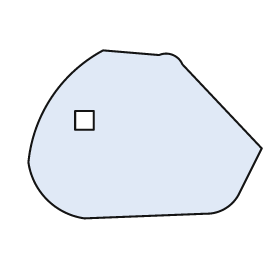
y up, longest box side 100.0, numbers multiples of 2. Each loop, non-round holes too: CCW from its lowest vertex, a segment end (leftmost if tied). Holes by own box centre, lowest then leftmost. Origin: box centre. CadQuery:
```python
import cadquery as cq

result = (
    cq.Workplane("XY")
    .moveTo(-26.0, -36.0)
    .lineTo(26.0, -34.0)
    .threePointArc((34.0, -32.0), (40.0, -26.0))
    .lineTo(50.0, -6.0)
    .lineTo(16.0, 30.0)
    .threePointArc((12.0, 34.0), (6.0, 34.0))
    .lineTo(-18.0, 36.0)
    .threePointArc((-40.0, 16.0), (-50.0, -12.0))
    .threePointArc((-42.0, -28.0), (-26.0, -36.0))
    .close()
    .moveTo(-30.0, 2.0)
    .lineTo(-22.0, 2.0)
    .lineTo(-22.0, 10.0)
    .lineTo(-30.0, 10.0)
    .close()
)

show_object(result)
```